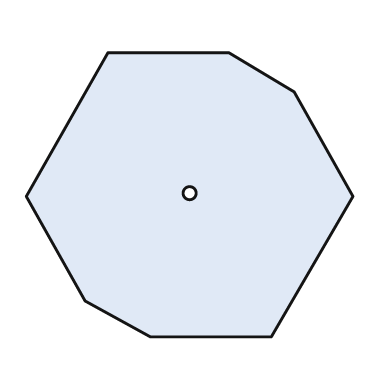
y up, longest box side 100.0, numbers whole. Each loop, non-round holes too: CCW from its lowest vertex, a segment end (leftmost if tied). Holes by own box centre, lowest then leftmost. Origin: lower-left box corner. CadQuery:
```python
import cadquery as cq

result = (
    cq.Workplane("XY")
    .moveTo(38.0, 0.0)
    .lineTo(75.0, 0.0)
    .lineTo(100.0, 43.0)
    .lineTo(82.0, 75.0)
    .lineTo(62.0, 87.0)
    .lineTo(25.0, 87.0)
    .lineTo(0.0, 43.0)
    .lineTo(18.0, 11.0)
    .close()
    .moveTo(50.0, 44.0)
    .circle(2.0)
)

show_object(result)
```